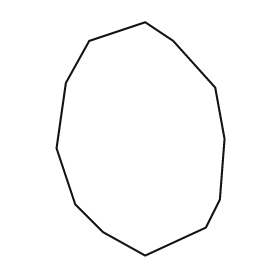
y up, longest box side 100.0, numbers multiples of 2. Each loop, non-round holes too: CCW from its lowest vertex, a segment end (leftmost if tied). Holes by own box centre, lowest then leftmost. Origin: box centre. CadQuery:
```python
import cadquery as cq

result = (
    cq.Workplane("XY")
    .moveTo(2.0, -50.0)
    .lineTo(28.0, -38.0)
    .lineTo(34.0, -26.0)
    .lineTo(36.0, 0.0)
    .lineTo(32.0, 22.0)
    .lineTo(14.0, 42.0)
    .lineTo(2.0, 50.0)
    .lineTo(-22.0, 42.0)
    .lineTo(-32.0, 24.0)
    .lineTo(-36.0, -4.0)
    .lineTo(-28.0, -28.0)
    .lineTo(-16.0, -40.0)
    .close()
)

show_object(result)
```